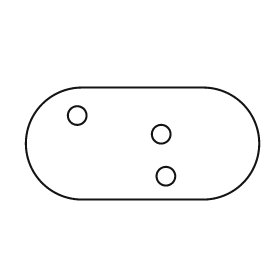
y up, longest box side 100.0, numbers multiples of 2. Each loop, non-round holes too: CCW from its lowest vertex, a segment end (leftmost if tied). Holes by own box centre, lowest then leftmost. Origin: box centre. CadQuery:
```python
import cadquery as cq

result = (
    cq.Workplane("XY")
    .moveTo(-26.0, -24.0)
    .lineTo(26.0, -24.0)
    .threePointArc((50.0, 0.0), (26.0, 24.0))
    .lineTo(-26.0, 24.0)
    .threePointArc((-50.0, 0.0), (-26.0, -24.0))
    .close()
    .moveTo(10.0, -14.0)
    .circle(4.0)
    .moveTo(8.0, 4.0)
    .circle(4.0)
    .moveTo(-28.0, 12.0)
    .circle(4.0)
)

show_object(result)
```